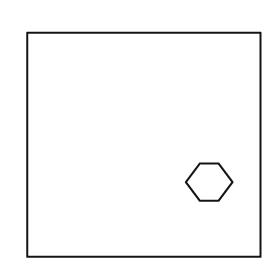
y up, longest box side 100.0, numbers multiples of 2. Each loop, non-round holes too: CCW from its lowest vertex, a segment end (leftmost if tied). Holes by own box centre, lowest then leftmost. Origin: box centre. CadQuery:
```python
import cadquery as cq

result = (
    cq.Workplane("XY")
    .moveTo(-50.0, -48.0)
    .lineTo(50.0, -48.0)
    .lineTo(50.0, 48.0)
    .lineTo(-50.0, 48.0)
    .close()
    .moveTo(24.0, -24.0)
    .lineTo(32.0, -24.0)
    .lineTo(38.0, -16.0)
    .lineTo(32.0, -8.0)
    .lineTo(24.0, -8.0)
    .lineTo(18.0, -16.0)
    .close()
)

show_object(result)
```